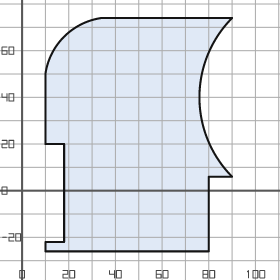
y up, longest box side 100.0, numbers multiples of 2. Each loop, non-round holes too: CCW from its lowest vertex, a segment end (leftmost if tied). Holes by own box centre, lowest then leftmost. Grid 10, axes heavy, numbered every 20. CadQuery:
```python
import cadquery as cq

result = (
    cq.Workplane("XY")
    .moveTo(10.0, -26.0)
    .lineTo(80.0, -26.0)
    .lineTo(80.0, 6.0)
    .lineTo(90.0, 6.0)
    .threePointArc((76.0, 40.0), (90.0, 74.0))
    .lineTo(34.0, 74.0)
    .threePointArc((18.0, 66.0), (10.0, 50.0))
    .lineTo(10.0, 20.0)
    .lineTo(18.0, 20.0)
    .lineTo(18.0, -22.0)
    .lineTo(10.0, -22.0)
    .close()
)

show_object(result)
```